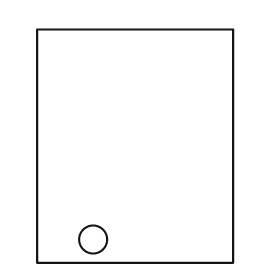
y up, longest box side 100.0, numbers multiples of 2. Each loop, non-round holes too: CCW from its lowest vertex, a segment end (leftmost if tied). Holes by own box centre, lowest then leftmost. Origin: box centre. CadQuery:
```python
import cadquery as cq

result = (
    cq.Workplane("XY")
    .moveTo(-42.0, -50.0)
    .lineTo(42.0, -50.0)
    .lineTo(42.0, 50.0)
    .lineTo(-42.0, 50.0)
    .close()
    .moveTo(-18.0, -40.0)
    .circle(6.0)
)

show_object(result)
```